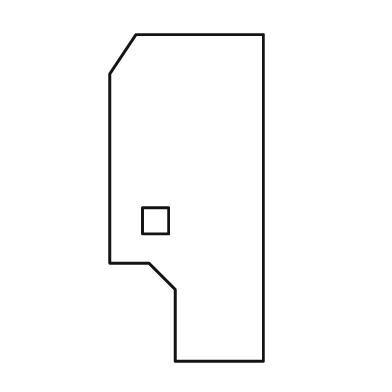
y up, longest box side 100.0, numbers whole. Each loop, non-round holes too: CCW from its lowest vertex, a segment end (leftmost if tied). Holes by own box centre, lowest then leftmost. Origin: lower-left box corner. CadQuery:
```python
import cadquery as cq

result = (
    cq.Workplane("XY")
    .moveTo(20.0, 0.0)
    .lineTo(47.0, 0.0)
    .lineTo(47.0, 100.0)
    .lineTo(8.0, 100.0)
    .lineTo(0.0, 88.0)
    .lineTo(0.0, 30.0)
    .lineTo(12.0, 30.0)
    .lineTo(20.0, 22.0)
    .close()
    .moveTo(10.0, 39.0)
    .lineTo(18.0, 39.0)
    .lineTo(18.0, 47.0)
    .lineTo(10.0, 47.0)
    .close()
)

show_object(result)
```